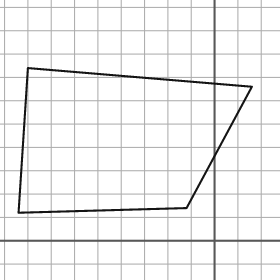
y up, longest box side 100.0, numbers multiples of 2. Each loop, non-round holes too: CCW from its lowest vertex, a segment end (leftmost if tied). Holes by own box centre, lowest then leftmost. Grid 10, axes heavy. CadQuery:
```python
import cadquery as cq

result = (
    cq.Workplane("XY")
    .moveTo(-84.0, 12.0)
    .lineTo(-12.0, 14.0)
    .lineTo(16.0, 66.0)
    .lineTo(-80.0, 74.0)
    .close()
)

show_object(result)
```